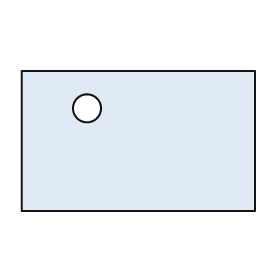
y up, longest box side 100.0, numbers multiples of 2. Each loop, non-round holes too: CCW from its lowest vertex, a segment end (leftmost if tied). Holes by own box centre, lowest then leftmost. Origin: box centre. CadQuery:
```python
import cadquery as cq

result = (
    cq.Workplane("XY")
    .moveTo(-50.0, -30.0)
    .lineTo(50.0, -30.0)
    .lineTo(50.0, 30.0)
    .lineTo(-50.0, 30.0)
    .close()
    .moveTo(-22.0, 14.0)
    .circle(6.0)
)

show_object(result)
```